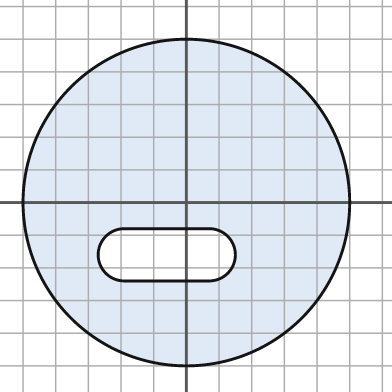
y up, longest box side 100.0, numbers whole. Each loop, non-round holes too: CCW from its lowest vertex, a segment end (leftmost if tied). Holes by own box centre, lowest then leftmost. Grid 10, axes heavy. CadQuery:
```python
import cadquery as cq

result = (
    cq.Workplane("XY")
    .moveTo(0.0, 0.0)
    .circle(50.0)
    .moveTo(-19.0, -24.0)
    .lineTo(7.0, -24.0)
    .threePointArc((15.0, -16.0), (7.0, -8.0))
    .lineTo(-19.0, -8.0)
    .threePointArc((-27.0, -16.0), (-19.0, -24.0))
    .close()
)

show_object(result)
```